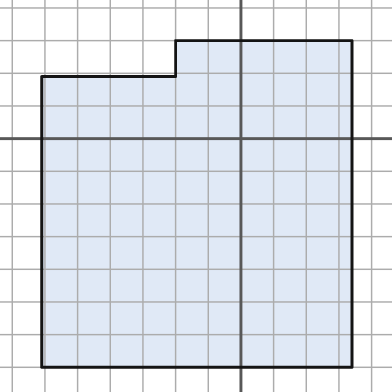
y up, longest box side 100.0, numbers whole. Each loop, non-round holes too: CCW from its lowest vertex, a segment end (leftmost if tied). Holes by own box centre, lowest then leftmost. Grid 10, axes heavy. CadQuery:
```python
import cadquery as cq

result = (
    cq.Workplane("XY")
    .moveTo(-61.0, -70.0)
    .lineTo(34.0, -70.0)
    .lineTo(34.0, 30.0)
    .lineTo(-20.0, 30.0)
    .lineTo(-20.0, 19.0)
    .lineTo(-61.0, 19.0)
    .close()
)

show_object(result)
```